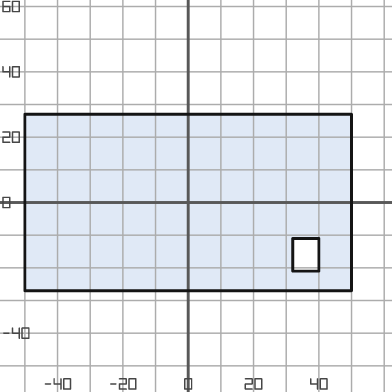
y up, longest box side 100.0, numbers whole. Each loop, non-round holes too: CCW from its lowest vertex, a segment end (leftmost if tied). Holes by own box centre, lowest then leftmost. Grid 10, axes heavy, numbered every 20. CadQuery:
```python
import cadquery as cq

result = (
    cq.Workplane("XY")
    .moveTo(-50.0, -27.0)
    .lineTo(50.0, -27.0)
    .lineTo(50.0, 27.0)
    .lineTo(-50.0, 27.0)
    .close()
    .moveTo(32.0, -21.0)
    .lineTo(40.0, -21.0)
    .lineTo(40.0, -11.0)
    .lineTo(32.0, -11.0)
    .close()
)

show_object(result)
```